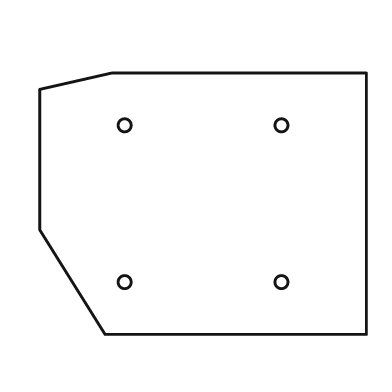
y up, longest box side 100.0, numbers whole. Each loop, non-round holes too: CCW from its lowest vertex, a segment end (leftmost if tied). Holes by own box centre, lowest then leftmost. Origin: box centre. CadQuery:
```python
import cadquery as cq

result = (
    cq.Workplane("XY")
    .moveTo(-30.0, -40.0)
    .lineTo(50.0, -40.0)
    .lineTo(50.0, 40.0)
    .lineTo(-28.0, 40.0)
    .lineTo(-50.0, 35.0)
    .lineTo(-50.0, -8.0)
    .close()
    .moveTo(-24.0, -24.0)
    .circle(2.0)
    .moveTo(24.0, -24.0)
    .circle(2.0)
    .moveTo(-24.0, 24.0)
    .circle(2.0)
    .moveTo(24.0, 24.0)
    .circle(2.0)
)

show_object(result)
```